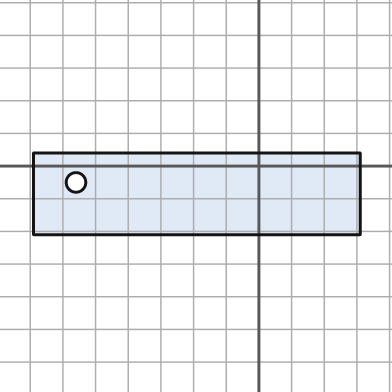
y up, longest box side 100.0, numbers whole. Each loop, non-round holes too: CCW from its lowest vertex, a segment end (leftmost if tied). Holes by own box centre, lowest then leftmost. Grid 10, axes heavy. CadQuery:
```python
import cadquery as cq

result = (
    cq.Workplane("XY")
    .moveTo(-69.0, -21.0)
    .lineTo(31.0, -21.0)
    .lineTo(31.0, 4.0)
    .lineTo(-69.0, 4.0)
    .close()
    .moveTo(-56.0, -5.0)
    .circle(3.0)
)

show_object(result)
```